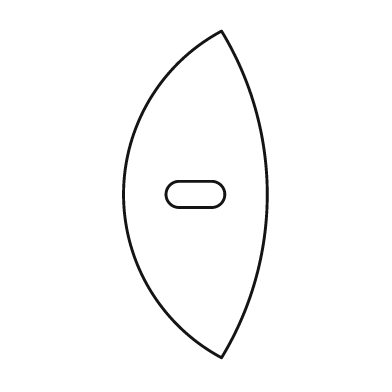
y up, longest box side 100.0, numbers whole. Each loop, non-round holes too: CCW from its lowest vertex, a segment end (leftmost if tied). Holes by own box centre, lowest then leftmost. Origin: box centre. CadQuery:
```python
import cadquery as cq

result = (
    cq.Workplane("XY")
    .moveTo(8.0, -50.0)
    .threePointArc((22.0, 0.0), (8.0, 50.0))
    .threePointArc((-22.0, 0.0), (8.0, -50.0))
    .close()
    .moveTo(-5.0, -4.0)
    .lineTo(5.0, -4.0)
    .threePointArc((9.0, 0.0), (5.0, 4.0))
    .lineTo(-5.0, 4.0)
    .threePointArc((-9.0, 0.0), (-5.0, -4.0))
    .close()
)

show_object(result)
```